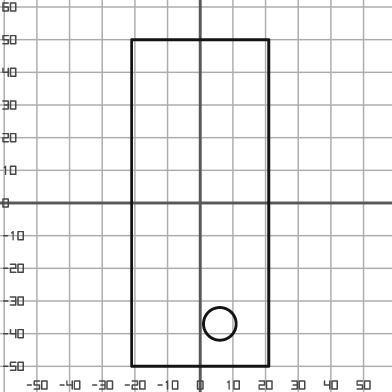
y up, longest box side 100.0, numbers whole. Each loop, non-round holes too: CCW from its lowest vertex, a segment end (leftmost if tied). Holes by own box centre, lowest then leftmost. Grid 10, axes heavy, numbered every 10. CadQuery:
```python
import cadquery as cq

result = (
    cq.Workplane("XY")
    .moveTo(-21.0, -50.0)
    .lineTo(21.0, -50.0)
    .lineTo(21.0, 50.0)
    .lineTo(-21.0, 50.0)
    .close()
    .moveTo(6.0, -37.0)
    .circle(5.0)
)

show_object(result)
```